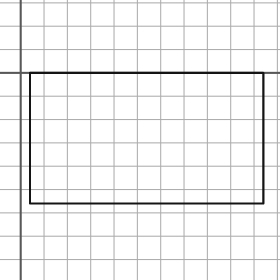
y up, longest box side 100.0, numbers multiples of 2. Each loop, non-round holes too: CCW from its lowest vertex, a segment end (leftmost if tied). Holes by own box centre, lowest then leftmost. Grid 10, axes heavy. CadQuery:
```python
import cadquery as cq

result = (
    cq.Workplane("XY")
    .moveTo(4.0, -56.0)
    .lineTo(104.0, -56.0)
    .lineTo(104.0, 0.0)
    .lineTo(4.0, 0.0)
    .close()
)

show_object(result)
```